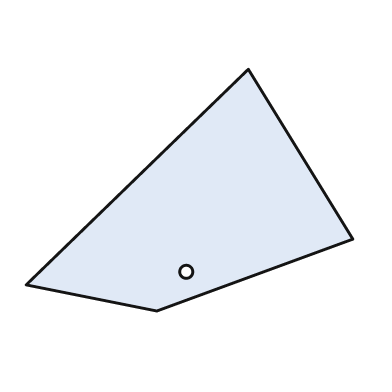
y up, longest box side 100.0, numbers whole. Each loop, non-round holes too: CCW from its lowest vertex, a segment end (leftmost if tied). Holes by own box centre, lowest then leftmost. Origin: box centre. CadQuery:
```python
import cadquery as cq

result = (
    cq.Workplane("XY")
    .moveTo(-10.0, -37.0)
    .lineTo(50.0, -15.0)
    .lineTo(18.0, 37.0)
    .lineTo(-50.0, -29.0)
    .close()
    .moveTo(-1.0, -25.0)
    .circle(2.0)
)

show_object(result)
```